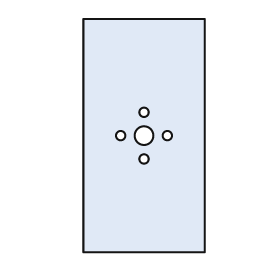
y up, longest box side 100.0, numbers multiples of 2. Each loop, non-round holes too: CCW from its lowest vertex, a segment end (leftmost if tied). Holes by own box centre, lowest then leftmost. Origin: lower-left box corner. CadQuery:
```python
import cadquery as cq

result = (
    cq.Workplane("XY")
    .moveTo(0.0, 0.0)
    .lineTo(52.0, 0.0)
    .lineTo(52.0, 100.0)
    .lineTo(0.0, 100.0)
    .close()
    .moveTo(26.0, 40.0)
    .circle(2.0)
    .moveTo(16.0, 50.0)
    .circle(2.0)
    .moveTo(26.0, 50.0)
    .circle(4.0)
    .moveTo(36.0, 50.0)
    .circle(2.0)
    .moveTo(26.0, 60.0)
    .circle(2.0)
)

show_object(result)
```